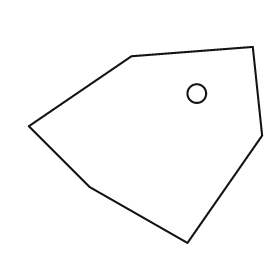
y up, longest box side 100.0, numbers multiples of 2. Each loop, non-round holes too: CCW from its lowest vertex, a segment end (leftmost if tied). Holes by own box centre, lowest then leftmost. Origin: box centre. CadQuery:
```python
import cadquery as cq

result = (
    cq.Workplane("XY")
    .moveTo(18.0, -42.0)
    .lineTo(50.0, 4.0)
    .lineTo(46.0, 42.0)
    .lineTo(-6.0, 38.0)
    .lineTo(-50.0, 8.0)
    .lineTo(-24.0, -18.0)
    .close()
    .moveTo(22.0, 22.0)
    .circle(4.0)
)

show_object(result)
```